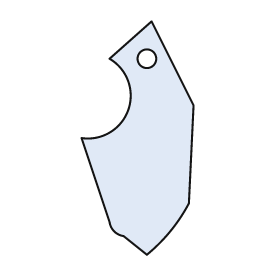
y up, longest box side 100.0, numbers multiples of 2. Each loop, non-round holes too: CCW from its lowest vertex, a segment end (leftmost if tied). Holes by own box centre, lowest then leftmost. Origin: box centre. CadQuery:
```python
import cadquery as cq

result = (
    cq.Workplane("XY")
    .moveTo(4.0, -50.0)
    .threePointArc((14.0, -40.0), (22.0, -28.0))
    .lineTo(24.0, 14.0)
    .lineTo(6.0, 50.0)
    .lineTo(-12.0, 34.0)
    .threePointArc((-4.0, 12.0), (-24.0, 0.0))
    .lineTo(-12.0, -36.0)
    .threePointArc((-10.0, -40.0), (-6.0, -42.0))
    .close()
    .moveTo(4.0, 34.0)
    .circle(4.0)
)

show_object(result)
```